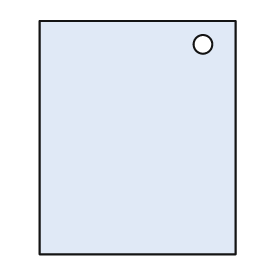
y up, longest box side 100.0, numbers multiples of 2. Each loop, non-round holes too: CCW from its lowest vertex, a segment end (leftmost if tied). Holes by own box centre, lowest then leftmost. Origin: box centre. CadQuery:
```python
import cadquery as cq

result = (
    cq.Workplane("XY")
    .moveTo(-42.0, -50.0)
    .lineTo(42.0, -50.0)
    .lineTo(42.0, 50.0)
    .lineTo(-42.0, 50.0)
    .close()
    .moveTo(28.0, 40.0)
    .circle(4.0)
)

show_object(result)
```